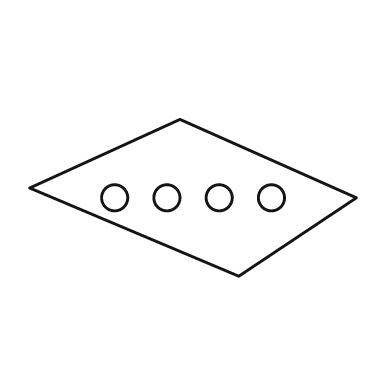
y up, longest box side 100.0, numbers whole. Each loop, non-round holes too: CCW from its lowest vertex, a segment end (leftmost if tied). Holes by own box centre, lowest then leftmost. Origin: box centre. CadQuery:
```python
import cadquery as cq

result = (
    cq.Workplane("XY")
    .moveTo(14.0, -24.0)
    .lineTo(50.0, 0.0)
    .lineTo(-4.0, 24.0)
    .lineTo(-50.0, 3.0)
    .close()
    .moveTo(-24.0, 0.0)
    .circle(4.0)
    .moveTo(-8.0, 0.0)
    .circle(4.0)
    .moveTo(8.0, 0.0)
    .circle(4.0)
    .moveTo(24.0, 0.0)
    .circle(4.0)
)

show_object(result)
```